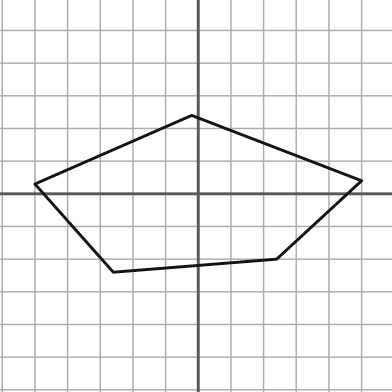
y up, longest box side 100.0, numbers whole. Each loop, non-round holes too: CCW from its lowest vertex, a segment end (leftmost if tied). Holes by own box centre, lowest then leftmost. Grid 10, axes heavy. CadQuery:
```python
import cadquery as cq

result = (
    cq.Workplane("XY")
    .moveTo(-26.0, -24.0)
    .lineTo(24.0, -20.0)
    .lineTo(50.0, 4.0)
    .lineTo(-2.0, 24.0)
    .lineTo(-50.0, 3.0)
    .close()
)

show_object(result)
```